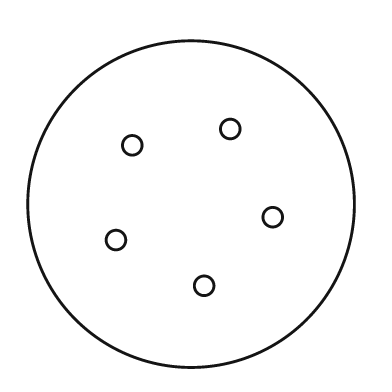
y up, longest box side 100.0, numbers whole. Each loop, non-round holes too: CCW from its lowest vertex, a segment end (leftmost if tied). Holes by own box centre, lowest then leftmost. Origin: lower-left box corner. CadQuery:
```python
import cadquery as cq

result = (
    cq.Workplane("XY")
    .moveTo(50.0, 50.0)
    .circle(50.0)
    .moveTo(54.0, 25.0)
    .circle(3.0)
    .moveTo(27.0, 39.0)
    .circle(3.0)
    .moveTo(75.0, 46.0)
    .circle(3.0)
    .moveTo(32.0, 68.0)
    .circle(3.0)
    .moveTo(62.0, 73.0)
    .circle(3.0)
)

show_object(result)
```